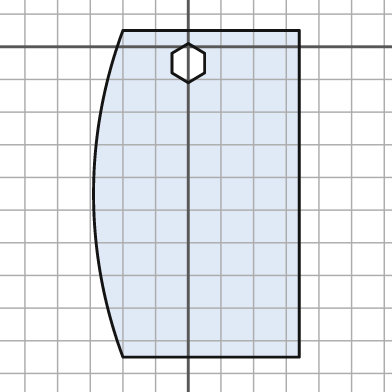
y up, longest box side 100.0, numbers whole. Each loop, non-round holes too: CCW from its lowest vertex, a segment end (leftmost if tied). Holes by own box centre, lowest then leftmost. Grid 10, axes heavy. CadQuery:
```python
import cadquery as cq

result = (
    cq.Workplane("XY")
    .moveTo(-20.0, -95.0)
    .lineTo(34.0, -95.0)
    .lineTo(34.0, 5.0)
    .lineTo(-20.0, 5.0)
    .threePointArc((-29.0, -45.0), (-20.0, -95.0))
    .close()
    .moveTo(0.0, -11.0)
    .lineTo(5.0, -8.0)
    .lineTo(5.0, -2.0)
    .lineTo(0.0, 1.0)
    .lineTo(-5.0, -2.0)
    .lineTo(-5.0, -8.0)
    .close()
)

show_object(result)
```